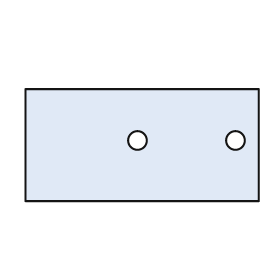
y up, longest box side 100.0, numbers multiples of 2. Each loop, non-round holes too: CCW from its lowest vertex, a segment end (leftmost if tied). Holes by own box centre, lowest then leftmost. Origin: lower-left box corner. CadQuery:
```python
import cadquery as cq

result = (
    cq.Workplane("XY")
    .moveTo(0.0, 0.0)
    .lineTo(100.0, 0.0)
    .lineTo(100.0, 48.0)
    .lineTo(0.0, 48.0)
    .close()
    .moveTo(48.0, 26.0)
    .circle(4.0)
    .moveTo(90.0, 26.0)
    .circle(4.0)
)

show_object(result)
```